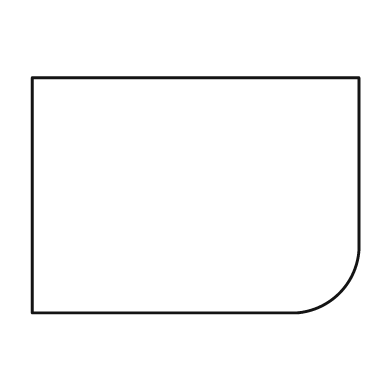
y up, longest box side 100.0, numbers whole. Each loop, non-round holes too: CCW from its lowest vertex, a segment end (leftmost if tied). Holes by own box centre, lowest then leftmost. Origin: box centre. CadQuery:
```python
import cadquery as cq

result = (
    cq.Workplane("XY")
    .moveTo(-50.0, -36.0)
    .lineTo(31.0, -36.0)
    .threePointArc((44.0, -30.0), (50.0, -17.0))
    .lineTo(50.0, 36.0)
    .lineTo(-50.0, 36.0)
    .close()
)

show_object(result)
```